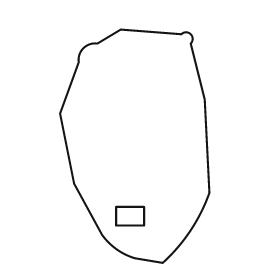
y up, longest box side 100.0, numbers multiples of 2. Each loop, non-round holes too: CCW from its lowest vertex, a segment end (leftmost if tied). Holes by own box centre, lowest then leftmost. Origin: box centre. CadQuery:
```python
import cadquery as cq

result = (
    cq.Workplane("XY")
    .moveTo(12.0, -50.0)
    .threePointArc((24.0, -36.0), (32.0, -20.0))
    .lineTo(30.0, 20.0)
    .lineTo(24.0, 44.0)
    .threePointArc((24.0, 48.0), (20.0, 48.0))
    .lineTo(-6.0, 50.0)
    .lineTo(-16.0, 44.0)
    .threePointArc((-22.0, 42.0), (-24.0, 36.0))
    .lineTo(-32.0, 14.0)
    .lineTo(-26.0, -16.0)
    .lineTo(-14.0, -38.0)
    .threePointArc((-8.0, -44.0), (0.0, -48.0))
    .close()
    .moveTo(-8.0, -34.0)
    .lineTo(4.0, -34.0)
    .lineTo(4.0, -26.0)
    .lineTo(-8.0, -26.0)
    .close()
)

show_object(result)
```